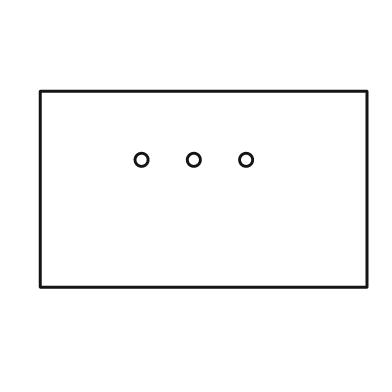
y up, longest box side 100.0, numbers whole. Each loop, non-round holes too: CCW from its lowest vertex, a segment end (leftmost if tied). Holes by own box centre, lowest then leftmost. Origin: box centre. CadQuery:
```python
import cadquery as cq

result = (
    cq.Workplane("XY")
    .moveTo(-50.0, -30.0)
    .lineTo(50.0, -30.0)
    .lineTo(50.0, 30.0)
    .lineTo(-50.0, 30.0)
    .close()
    .moveTo(-19.0, 9.0)
    .circle(2.0)
    .moveTo(-3.0, 9.0)
    .circle(2.0)
    .moveTo(13.0, 9.0)
    .circle(2.0)
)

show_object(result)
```